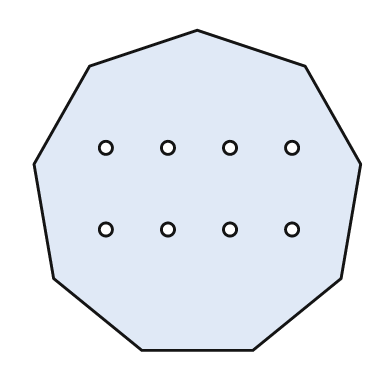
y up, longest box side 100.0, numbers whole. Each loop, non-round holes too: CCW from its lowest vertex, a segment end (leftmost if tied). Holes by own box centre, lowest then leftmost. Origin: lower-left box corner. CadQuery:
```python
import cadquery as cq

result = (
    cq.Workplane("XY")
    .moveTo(33.0, 0.0)
    .lineTo(67.0, 0.0)
    .lineTo(94.0, 22.0)
    .lineTo(100.0, 57.0)
    .lineTo(83.0, 87.0)
    .lineTo(50.0, 98.0)
    .lineTo(17.0, 87.0)
    .lineTo(0.0, 57.0)
    .lineTo(6.0, 22.0)
    .close()
    .moveTo(22.0, 37.0)
    .circle(2.0)
    .moveTo(41.0, 37.0)
    .circle(2.0)
    .moveTo(60.0, 37.0)
    .circle(2.0)
    .moveTo(79.0, 37.0)
    .circle(2.0)
    .moveTo(22.0, 62.0)
    .circle(2.0)
    .moveTo(41.0, 62.0)
    .circle(2.0)
    .moveTo(60.0, 62.0)
    .circle(2.0)
    .moveTo(79.0, 62.0)
    .circle(2.0)
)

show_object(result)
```